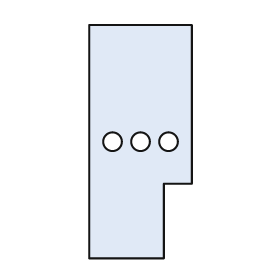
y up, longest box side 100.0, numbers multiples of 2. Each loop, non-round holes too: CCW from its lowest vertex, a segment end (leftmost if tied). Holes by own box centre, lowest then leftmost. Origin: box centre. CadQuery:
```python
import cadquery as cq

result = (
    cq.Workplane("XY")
    .moveTo(-22.0, -50.0)
    .lineTo(10.0, -50.0)
    .lineTo(10.0, -18.0)
    .lineTo(22.0, -18.0)
    .lineTo(22.0, 50.0)
    .lineTo(-22.0, 50.0)
    .close()
    .moveTo(-12.0, 0.0)
    .circle(4.0)
    .moveTo(0.0, 0.0)
    .circle(4.0)
    .moveTo(12.0, 0.0)
    .circle(4.0)
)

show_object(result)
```